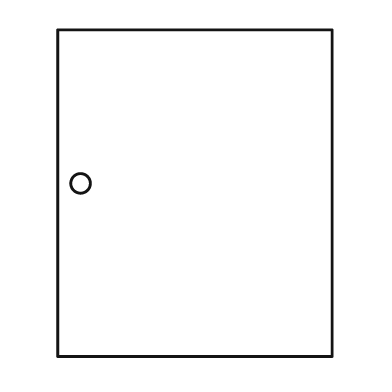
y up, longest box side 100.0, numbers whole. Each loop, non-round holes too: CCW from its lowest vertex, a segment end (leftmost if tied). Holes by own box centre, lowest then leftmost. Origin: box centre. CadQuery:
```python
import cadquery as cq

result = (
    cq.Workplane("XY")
    .moveTo(-42.0, -50.0)
    .lineTo(42.0, -50.0)
    .lineTo(42.0, 50.0)
    .lineTo(-42.0, 50.0)
    .close()
    .moveTo(-35.0, 3.0)
    .circle(3.0)
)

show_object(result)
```